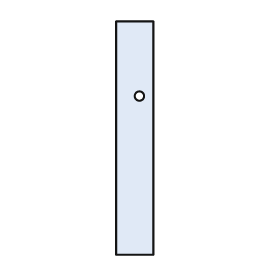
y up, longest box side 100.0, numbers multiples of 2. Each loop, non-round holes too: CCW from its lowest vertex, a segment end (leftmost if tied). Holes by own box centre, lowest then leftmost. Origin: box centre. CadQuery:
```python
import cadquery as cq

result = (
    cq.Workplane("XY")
    .moveTo(-8.0, -50.0)
    .lineTo(8.0, -50.0)
    .lineTo(8.0, 50.0)
    .lineTo(-8.0, 50.0)
    .close()
    .moveTo(2.0, 18.0)
    .circle(2.0)
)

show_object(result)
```